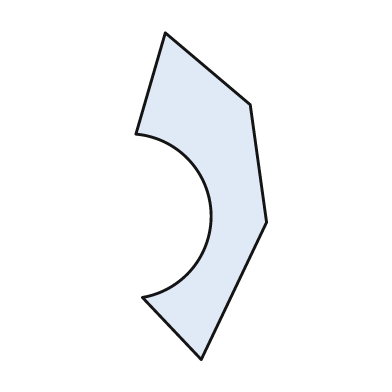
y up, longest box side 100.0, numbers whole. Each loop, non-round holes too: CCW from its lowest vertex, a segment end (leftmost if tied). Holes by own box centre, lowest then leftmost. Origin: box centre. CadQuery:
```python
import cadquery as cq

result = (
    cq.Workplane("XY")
    .moveTo(0.0, -50.0)
    .lineTo(20.0, -8.0)
    .lineTo(15.0, 28.0)
    .lineTo(-11.0, 50.0)
    .lineTo(-20.0, 19.0)
    .threePointArc((3.0, -5.0), (-18.0, -31.0))
    .close()
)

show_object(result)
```